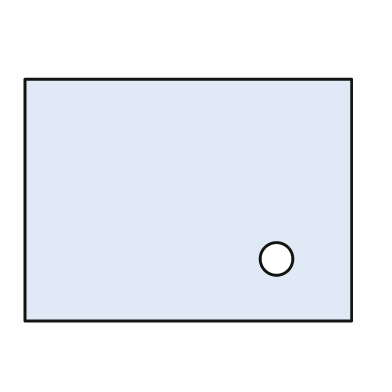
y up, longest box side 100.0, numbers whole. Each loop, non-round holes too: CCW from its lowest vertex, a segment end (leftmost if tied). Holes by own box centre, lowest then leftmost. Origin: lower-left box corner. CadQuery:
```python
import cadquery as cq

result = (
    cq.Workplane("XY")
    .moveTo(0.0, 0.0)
    .lineTo(100.0, 0.0)
    .lineTo(100.0, 74.0)
    .lineTo(0.0, 74.0)
    .close()
    .moveTo(77.0, 19.0)
    .circle(5.0)
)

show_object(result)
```